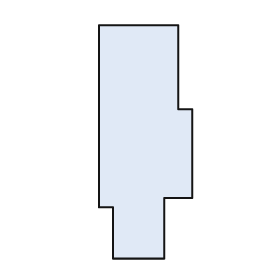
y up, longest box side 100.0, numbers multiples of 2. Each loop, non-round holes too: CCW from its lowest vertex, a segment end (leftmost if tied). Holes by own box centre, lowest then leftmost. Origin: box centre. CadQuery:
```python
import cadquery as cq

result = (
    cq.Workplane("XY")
    .moveTo(-14.0, -50.0)
    .lineTo(8.0, -50.0)
    .lineTo(8.0, -24.0)
    .lineTo(20.0, -24.0)
    .lineTo(20.0, 14.0)
    .lineTo(14.0, 14.0)
    .lineTo(14.0, 50.0)
    .lineTo(-20.0, 50.0)
    .lineTo(-20.0, -28.0)
    .lineTo(-14.0, -28.0)
    .close()
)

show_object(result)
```